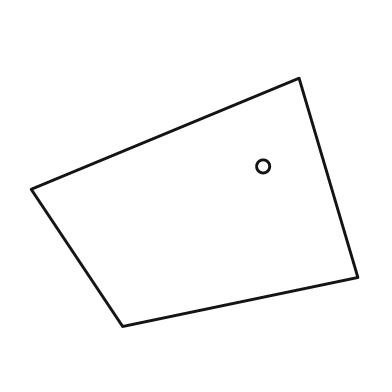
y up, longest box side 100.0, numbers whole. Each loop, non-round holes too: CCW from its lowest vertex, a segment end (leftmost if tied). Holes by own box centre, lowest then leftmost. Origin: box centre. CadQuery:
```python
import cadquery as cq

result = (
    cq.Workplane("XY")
    .moveTo(-22.0, -38.0)
    .lineTo(50.0, -23.0)
    .lineTo(32.0, 38.0)
    .lineTo(-50.0, 4.0)
    .close()
    .moveTo(21.0, 11.0)
    .circle(2.0)
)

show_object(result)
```